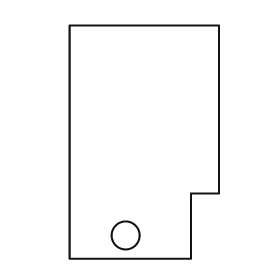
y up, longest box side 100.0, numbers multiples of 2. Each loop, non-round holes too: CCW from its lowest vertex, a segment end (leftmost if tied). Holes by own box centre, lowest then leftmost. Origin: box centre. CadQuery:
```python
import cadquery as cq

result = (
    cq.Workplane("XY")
    .moveTo(-32.0, -50.0)
    .lineTo(20.0, -50.0)
    .lineTo(20.0, -22.0)
    .lineTo(32.0, -22.0)
    .lineTo(32.0, 50.0)
    .lineTo(-32.0, 50.0)
    .close()
    .moveTo(-8.0, -40.0)
    .circle(6.0)
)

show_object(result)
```